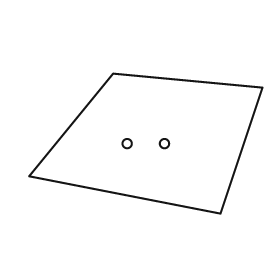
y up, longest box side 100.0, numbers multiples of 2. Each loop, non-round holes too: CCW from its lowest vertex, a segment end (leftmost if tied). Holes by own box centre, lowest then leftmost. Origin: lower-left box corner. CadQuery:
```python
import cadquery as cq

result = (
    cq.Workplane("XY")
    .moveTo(82.0, 0.0)
    .lineTo(100.0, 54.0)
    .lineTo(36.0, 60.0)
    .lineTo(0.0, 16.0)
    .close()
    .moveTo(42.0, 30.0)
    .circle(2.0)
    .moveTo(58.0, 30.0)
    .circle(2.0)
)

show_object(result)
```